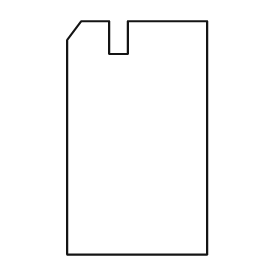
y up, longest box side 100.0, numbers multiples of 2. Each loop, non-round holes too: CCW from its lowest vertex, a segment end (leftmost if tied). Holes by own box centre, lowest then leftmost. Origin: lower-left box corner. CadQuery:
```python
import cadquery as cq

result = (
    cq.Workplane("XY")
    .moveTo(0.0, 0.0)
    .lineTo(60.0, 0.0)
    .lineTo(60.0, 100.0)
    .lineTo(26.0, 100.0)
    .lineTo(26.0, 86.0)
    .lineTo(18.0, 86.0)
    .lineTo(18.0, 100.0)
    .lineTo(6.0, 100.0)
    .lineTo(0.0, 92.0)
    .close()
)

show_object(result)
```